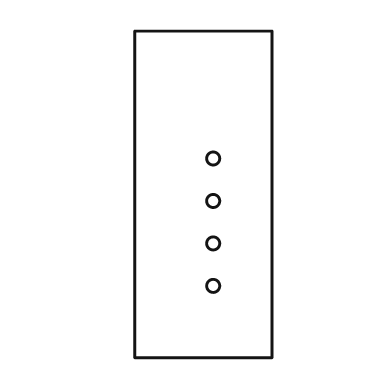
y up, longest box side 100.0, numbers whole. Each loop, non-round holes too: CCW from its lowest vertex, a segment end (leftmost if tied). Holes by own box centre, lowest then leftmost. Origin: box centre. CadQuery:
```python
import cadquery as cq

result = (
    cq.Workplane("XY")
    .moveTo(-21.0, -50.0)
    .lineTo(21.0, -50.0)
    .lineTo(21.0, 50.0)
    .lineTo(-21.0, 50.0)
    .close()
    .moveTo(3.0, -28.0)
    .circle(2.0)
    .moveTo(3.0, -15.0)
    .circle(2.0)
    .moveTo(3.0, -2.0)
    .circle(2.0)
    .moveTo(3.0, 11.0)
    .circle(2.0)
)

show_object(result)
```